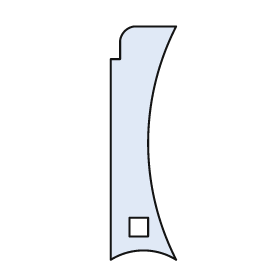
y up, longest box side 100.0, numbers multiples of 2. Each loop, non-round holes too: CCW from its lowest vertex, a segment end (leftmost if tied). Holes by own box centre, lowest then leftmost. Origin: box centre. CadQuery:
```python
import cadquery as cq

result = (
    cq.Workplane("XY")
    .moveTo(-14.0, -50.0)
    .threePointArc((0.0, -46.0), (14.0, -50.0))
    .threePointArc((2.0, 0.0), (14.0, 50.0))
    .lineTo(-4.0, 50.0)
    .threePointArc((-8.0, 48.0), (-10.0, 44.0))
    .lineTo(-10.0, 36.0)
    .lineTo(-14.0, 36.0)
    .close()
    .moveTo(-6.0, -40.0)
    .lineTo(2.0, -40.0)
    .lineTo(2.0, -32.0)
    .lineTo(-6.0, -32.0)
    .close()
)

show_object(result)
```